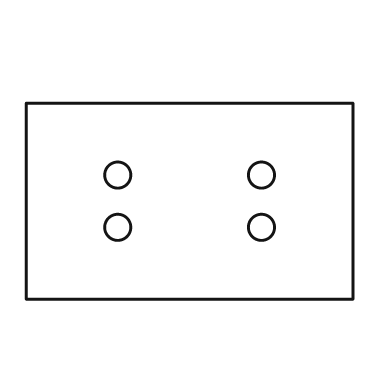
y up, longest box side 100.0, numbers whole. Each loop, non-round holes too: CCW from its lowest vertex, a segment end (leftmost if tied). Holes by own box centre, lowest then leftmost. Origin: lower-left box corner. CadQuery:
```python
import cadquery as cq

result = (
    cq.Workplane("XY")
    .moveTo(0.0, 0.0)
    .lineTo(100.0, 0.0)
    .lineTo(100.0, 60.0)
    .lineTo(0.0, 60.0)
    .close()
    .moveTo(28.0, 22.0)
    .circle(4.0)
    .moveTo(72.0, 22.0)
    .circle(4.0)
    .moveTo(28.0, 38.0)
    .circle(4.0)
    .moveTo(72.0, 38.0)
    .circle(4.0)
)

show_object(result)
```